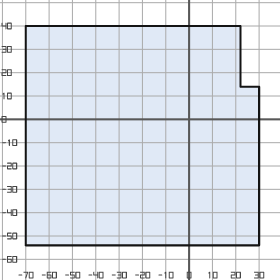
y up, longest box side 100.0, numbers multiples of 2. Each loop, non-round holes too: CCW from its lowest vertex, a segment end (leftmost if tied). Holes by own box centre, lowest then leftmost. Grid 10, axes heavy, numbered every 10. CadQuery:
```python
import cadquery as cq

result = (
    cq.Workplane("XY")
    .moveTo(-70.0, -54.0)
    .lineTo(30.0, -54.0)
    .lineTo(30.0, 14.0)
    .lineTo(22.0, 14.0)
    .lineTo(22.0, 40.0)
    .lineTo(-70.0, 40.0)
    .close()
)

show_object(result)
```